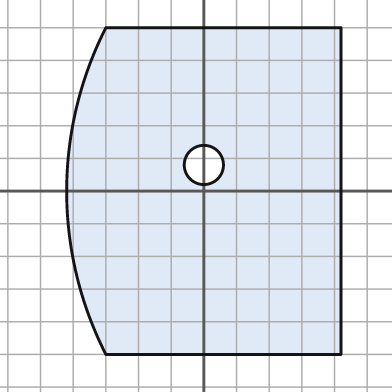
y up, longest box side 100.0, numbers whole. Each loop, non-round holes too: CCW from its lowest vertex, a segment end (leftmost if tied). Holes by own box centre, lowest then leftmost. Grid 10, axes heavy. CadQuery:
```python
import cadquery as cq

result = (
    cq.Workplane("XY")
    .moveTo(-30.0, -50.0)
    .lineTo(42.0, -50.0)
    .lineTo(42.0, 50.0)
    .lineTo(-30.0, 50.0)
    .threePointArc((-42.0, 0.0), (-30.0, -50.0))
    .close()
    .moveTo(0.0, 8.0)
    .circle(6.0)
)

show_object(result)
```